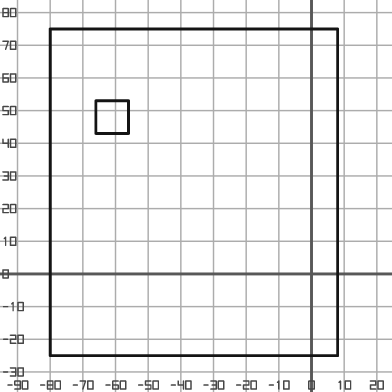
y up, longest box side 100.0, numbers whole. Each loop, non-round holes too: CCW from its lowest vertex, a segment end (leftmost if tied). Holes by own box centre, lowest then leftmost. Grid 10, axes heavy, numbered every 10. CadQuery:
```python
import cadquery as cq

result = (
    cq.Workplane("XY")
    .moveTo(-80.0, -25.0)
    .lineTo(8.0, -25.0)
    .lineTo(8.0, 75.0)
    .lineTo(-80.0, 75.0)
    .close()
    .moveTo(-66.0, 43.0)
    .lineTo(-56.0, 43.0)
    .lineTo(-56.0, 53.0)
    .lineTo(-66.0, 53.0)
    .close()
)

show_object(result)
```